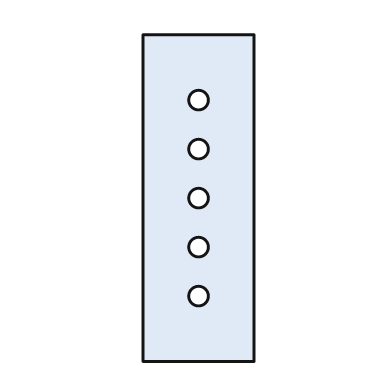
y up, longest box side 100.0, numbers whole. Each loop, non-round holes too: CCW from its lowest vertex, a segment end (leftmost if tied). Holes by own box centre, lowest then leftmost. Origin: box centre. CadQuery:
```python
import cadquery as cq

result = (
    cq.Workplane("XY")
    .moveTo(-17.0, -50.0)
    .lineTo(17.0, -50.0)
    .lineTo(17.0, 50.0)
    .lineTo(-17.0, 50.0)
    .close()
    .moveTo(0.0, -30.0)
    .circle(3.0)
    .moveTo(0.0, -15.0)
    .circle(3.0)
    .moveTo(0.0, 0.0)
    .circle(3.0)
    .moveTo(0.0, 15.0)
    .circle(3.0)
    .moveTo(0.0, 30.0)
    .circle(3.0)
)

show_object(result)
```